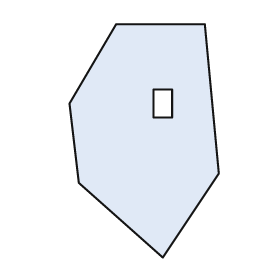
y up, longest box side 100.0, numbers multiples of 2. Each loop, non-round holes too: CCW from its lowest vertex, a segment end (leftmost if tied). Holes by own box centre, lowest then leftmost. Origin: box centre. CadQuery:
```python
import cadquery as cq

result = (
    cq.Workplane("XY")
    .moveTo(8.0, -50.0)
    .lineTo(32.0, -14.0)
    .lineTo(26.0, 50.0)
    .lineTo(-12.0, 50.0)
    .lineTo(-32.0, 16.0)
    .lineTo(-28.0, -18.0)
    .close()
    .moveTo(4.0, 10.0)
    .lineTo(12.0, 10.0)
    .lineTo(12.0, 22.0)
    .lineTo(4.0, 22.0)
    .close()
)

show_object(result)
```